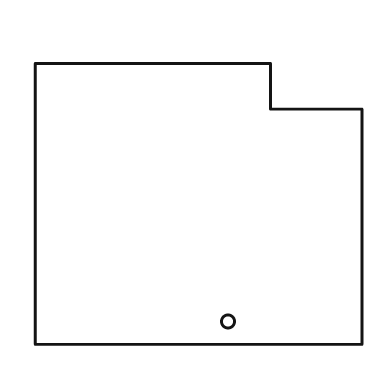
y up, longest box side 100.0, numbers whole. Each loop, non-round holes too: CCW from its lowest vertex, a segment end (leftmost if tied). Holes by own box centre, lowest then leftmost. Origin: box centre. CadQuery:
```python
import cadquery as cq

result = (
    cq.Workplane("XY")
    .moveTo(-50.0, -43.0)
    .lineTo(50.0, -43.0)
    .lineTo(50.0, 29.0)
    .lineTo(22.0, 29.0)
    .lineTo(22.0, 43.0)
    .lineTo(-50.0, 43.0)
    .close()
    .moveTo(9.0, -36.0)
    .circle(2.0)
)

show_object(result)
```